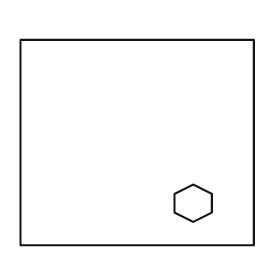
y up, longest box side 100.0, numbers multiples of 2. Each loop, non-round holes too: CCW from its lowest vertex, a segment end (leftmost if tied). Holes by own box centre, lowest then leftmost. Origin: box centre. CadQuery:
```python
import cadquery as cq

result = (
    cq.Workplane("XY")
    .moveTo(-50.0, -44.0)
    .lineTo(50.0, -44.0)
    .lineTo(50.0, 44.0)
    .lineTo(-50.0, 44.0)
    .close()
    .moveTo(24.0, -34.0)
    .lineTo(32.0, -30.0)
    .lineTo(32.0, -22.0)
    .lineTo(24.0, -18.0)
    .lineTo(16.0, -22.0)
    .lineTo(16.0, -30.0)
    .close()
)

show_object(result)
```